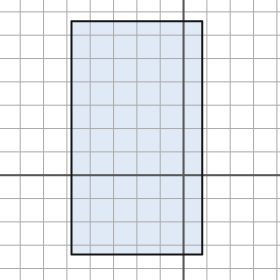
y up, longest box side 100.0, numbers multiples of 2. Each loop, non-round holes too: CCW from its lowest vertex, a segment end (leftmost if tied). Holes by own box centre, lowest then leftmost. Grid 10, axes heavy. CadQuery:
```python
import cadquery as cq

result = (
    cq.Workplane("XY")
    .moveTo(-48.0, -34.0)
    .lineTo(8.0, -34.0)
    .lineTo(8.0, 66.0)
    .lineTo(-48.0, 66.0)
    .close()
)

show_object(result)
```